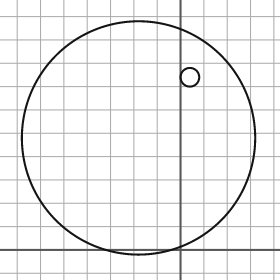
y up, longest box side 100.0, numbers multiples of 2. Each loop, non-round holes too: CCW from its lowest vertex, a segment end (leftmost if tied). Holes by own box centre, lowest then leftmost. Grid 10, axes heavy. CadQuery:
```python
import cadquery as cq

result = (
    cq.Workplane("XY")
    .moveTo(-18.0, 48.0)
    .circle(50.0)
    .moveTo(4.0, 74.0)
    .circle(4.0)
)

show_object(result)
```